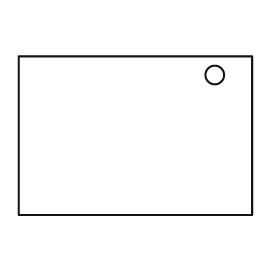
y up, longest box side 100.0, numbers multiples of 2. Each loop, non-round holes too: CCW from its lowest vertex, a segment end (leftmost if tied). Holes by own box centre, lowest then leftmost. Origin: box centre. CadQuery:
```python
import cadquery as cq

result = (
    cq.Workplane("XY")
    .moveTo(-50.0, -34.0)
    .lineTo(50.0, -34.0)
    .lineTo(50.0, 34.0)
    .lineTo(-50.0, 34.0)
    .close()
    .moveTo(34.0, 26.0)
    .circle(4.0)
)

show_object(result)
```